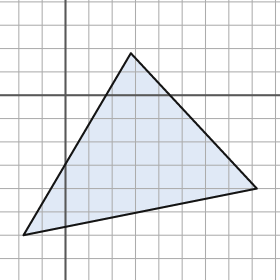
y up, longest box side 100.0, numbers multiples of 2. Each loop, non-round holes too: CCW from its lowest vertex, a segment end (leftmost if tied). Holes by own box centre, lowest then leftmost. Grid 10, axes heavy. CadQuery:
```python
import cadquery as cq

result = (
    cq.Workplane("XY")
    .moveTo(-18.0, -60.0)
    .lineTo(82.0, -40.0)
    .lineTo(28.0, 18.0)
    .close()
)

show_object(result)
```